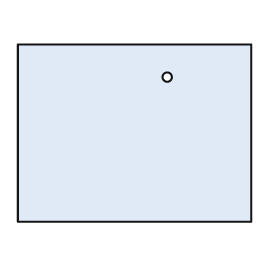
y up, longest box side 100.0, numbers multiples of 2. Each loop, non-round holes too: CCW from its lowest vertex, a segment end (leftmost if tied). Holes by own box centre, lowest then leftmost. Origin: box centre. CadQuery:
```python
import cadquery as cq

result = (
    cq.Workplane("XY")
    .moveTo(-50.0, -38.0)
    .lineTo(50.0, -38.0)
    .lineTo(50.0, 38.0)
    .lineTo(-50.0, 38.0)
    .close()
    .moveTo(14.0, 24.0)
    .circle(2.0)
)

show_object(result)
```